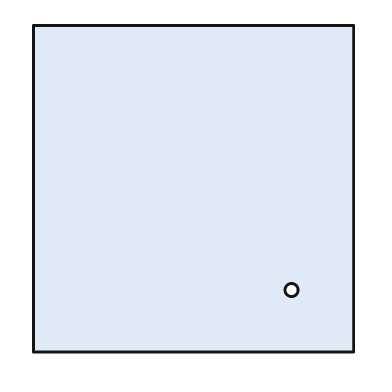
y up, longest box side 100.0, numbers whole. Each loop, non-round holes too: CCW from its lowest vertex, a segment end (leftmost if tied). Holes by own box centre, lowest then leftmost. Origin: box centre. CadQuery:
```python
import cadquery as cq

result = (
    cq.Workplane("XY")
    .moveTo(-49.0, -50.0)
    .lineTo(49.0, -50.0)
    .lineTo(49.0, 50.0)
    .lineTo(-49.0, 50.0)
    .close()
    .moveTo(30.0, -31.0)
    .circle(2.0)
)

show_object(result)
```